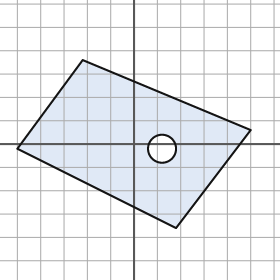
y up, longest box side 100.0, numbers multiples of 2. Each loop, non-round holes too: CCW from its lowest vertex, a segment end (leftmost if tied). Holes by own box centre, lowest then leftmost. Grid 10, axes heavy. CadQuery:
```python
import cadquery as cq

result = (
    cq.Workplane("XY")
    .moveTo(18.0, -36.0)
    .lineTo(50.0, 6.0)
    .lineTo(-22.0, 36.0)
    .lineTo(-50.0, -2.0)
    .close()
    .moveTo(12.0, -2.0)
    .circle(6.0)
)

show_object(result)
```